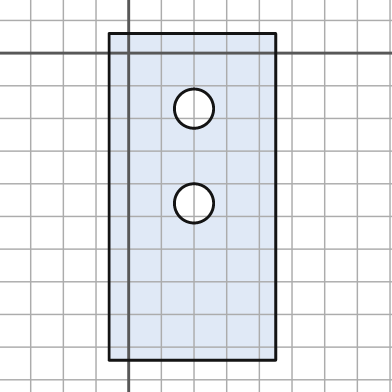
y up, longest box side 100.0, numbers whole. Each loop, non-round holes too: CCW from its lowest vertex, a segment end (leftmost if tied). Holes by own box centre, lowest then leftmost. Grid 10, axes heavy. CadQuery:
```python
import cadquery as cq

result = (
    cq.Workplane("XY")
    .moveTo(-6.0, -94.0)
    .lineTo(45.0, -94.0)
    .lineTo(45.0, 6.0)
    .lineTo(-6.0, 6.0)
    .close()
    .moveTo(20.0, -46.0)
    .circle(6.0)
    .moveTo(20.0, -17.0)
    .circle(6.0)
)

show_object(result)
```